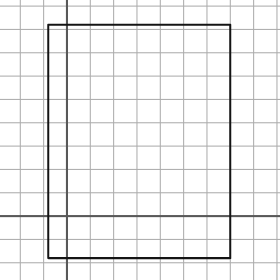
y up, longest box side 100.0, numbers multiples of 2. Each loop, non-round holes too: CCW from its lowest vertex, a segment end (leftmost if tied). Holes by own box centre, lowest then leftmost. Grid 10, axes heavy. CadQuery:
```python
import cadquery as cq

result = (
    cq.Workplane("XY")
    .moveTo(-8.0, -18.0)
    .lineTo(70.0, -18.0)
    .lineTo(70.0, 82.0)
    .lineTo(-8.0, 82.0)
    .close()
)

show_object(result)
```